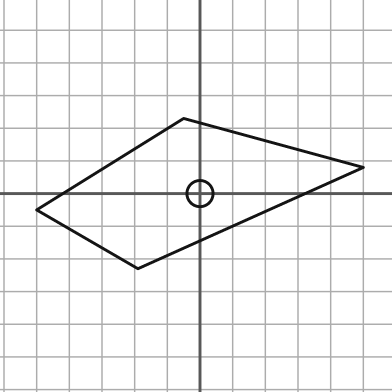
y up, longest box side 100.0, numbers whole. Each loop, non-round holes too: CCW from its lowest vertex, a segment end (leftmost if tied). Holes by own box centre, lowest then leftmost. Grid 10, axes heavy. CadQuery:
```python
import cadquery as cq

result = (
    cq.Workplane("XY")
    .moveTo(-19.0, -23.0)
    .lineTo(50.0, 8.0)
    .lineTo(-5.0, 23.0)
    .lineTo(-50.0, -5.0)
    .close()
    .moveTo(0.0, 0.0)
    .circle(4.0)
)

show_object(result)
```